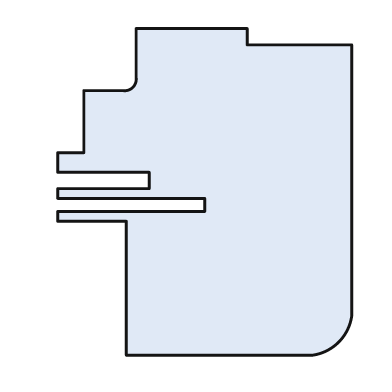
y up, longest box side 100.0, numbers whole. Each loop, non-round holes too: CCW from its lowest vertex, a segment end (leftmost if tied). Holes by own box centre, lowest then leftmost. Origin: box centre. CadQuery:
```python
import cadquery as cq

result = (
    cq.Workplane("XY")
    .moveTo(-24.0, -50.0)
    .lineTo(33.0, -50.0)
    .threePointArc((41.0, -46.0), (45.0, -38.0))
    .lineTo(45.0, 45.0)
    .lineTo(13.0, 45.0)
    .lineTo(13.0, 50.0)
    .lineTo(-21.0, 50.0)
    .lineTo(-21.0, 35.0)
    .threePointArc((-22.0, 32.0), (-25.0, 31.0))
    .lineTo(-37.0, 31.0)
    .lineTo(-37.0, 12.0)
    .lineTo(-45.0, 12.0)
    .lineTo(-45.0, 6.0)
    .lineTo(-17.0, 6.0)
    .lineTo(-17.0, 1.0)
    .lineTo(-45.0, 1.0)
    .lineTo(-45.0, -2.0)
    .lineTo(0.0, -2.0)
    .lineTo(0.0, -6.0)
    .lineTo(-45.0, -6.0)
    .lineTo(-45.0, -9.0)
    .lineTo(-24.0, -9.0)
    .close()
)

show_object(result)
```